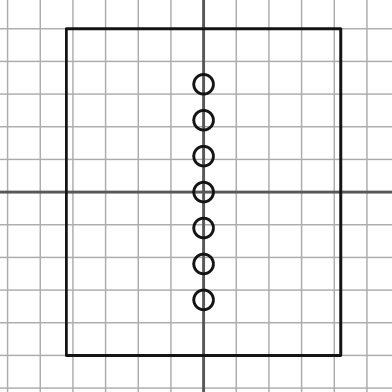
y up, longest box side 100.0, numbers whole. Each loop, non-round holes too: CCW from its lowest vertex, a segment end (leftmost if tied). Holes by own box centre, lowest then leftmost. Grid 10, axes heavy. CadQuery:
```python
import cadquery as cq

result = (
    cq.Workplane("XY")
    .moveTo(-42.0, -50.0)
    .lineTo(42.0, -50.0)
    .lineTo(42.0, 50.0)
    .lineTo(-42.0, 50.0)
    .close()
    .moveTo(0.0, -33.0)
    .circle(3.0)
    .moveTo(0.0, -22.0)
    .circle(3.0)
    .moveTo(0.0, -11.0)
    .circle(3.0)
    .moveTo(0.0, 0.0)
    .circle(3.0)
    .moveTo(0.0, 11.0)
    .circle(3.0)
    .moveTo(0.0, 22.0)
    .circle(3.0)
    .moveTo(0.0, 33.0)
    .circle(3.0)
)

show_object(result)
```